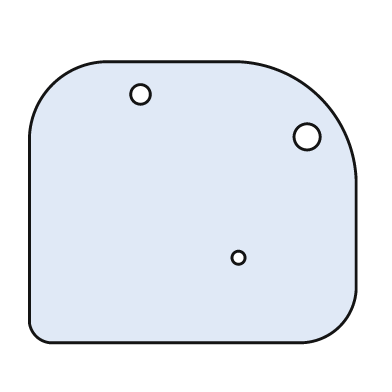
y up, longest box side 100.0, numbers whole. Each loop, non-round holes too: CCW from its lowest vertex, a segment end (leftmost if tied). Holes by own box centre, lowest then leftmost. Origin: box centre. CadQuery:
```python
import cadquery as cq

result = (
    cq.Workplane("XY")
    .moveTo(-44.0, -43.0)
    .lineTo(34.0, -43.0)
    .threePointArc((45.0, -38.0), (50.0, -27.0))
    .lineTo(50.0, 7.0)
    .threePointArc((39.0, 32.0), (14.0, 43.0))
    .lineTo(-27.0, 43.0)
    .threePointArc((-43.0, 36.0), (-50.0, 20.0))
    .lineTo(-50.0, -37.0)
    .threePointArc((-48.0, -41.0), (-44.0, -43.0))
    .close()
    .moveTo(14.0, -17.0)
    .circle(2.0)
    .moveTo(35.0, 20.0)
    .circle(4.0)
    .moveTo(-16.0, 33.0)
    .circle(3.0)
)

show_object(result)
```